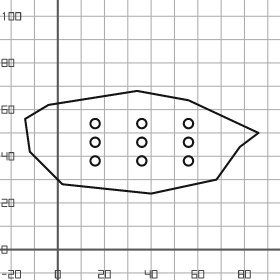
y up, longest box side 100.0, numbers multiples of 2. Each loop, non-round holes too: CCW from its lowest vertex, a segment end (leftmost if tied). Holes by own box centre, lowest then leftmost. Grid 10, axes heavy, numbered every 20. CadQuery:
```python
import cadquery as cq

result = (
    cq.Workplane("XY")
    .moveTo(40.0, 24.0)
    .lineTo(68.0, 30.0)
    .lineTo(78.0, 44.0)
    .lineTo(86.0, 50.0)
    .lineTo(56.0, 64.0)
    .lineTo(34.0, 68.0)
    .lineTo(-4.0, 62.0)
    .lineTo(-14.0, 56.0)
    .lineTo(-12.0, 42.0)
    .lineTo(2.0, 28.0)
    .close()
    .moveTo(16.0, 38.0)
    .circle(2.0)
    .moveTo(36.0, 38.0)
    .circle(2.0)
    .moveTo(56.0, 38.0)
    .circle(2.0)
    .moveTo(16.0, 46.0)
    .circle(2.0)
    .moveTo(36.0, 46.0)
    .circle(2.0)
    .moveTo(56.0, 46.0)
    .circle(2.0)
    .moveTo(16.0, 54.0)
    .circle(2.0)
    .moveTo(36.0, 54.0)
    .circle(2.0)
    .moveTo(56.0, 54.0)
    .circle(2.0)
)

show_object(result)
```